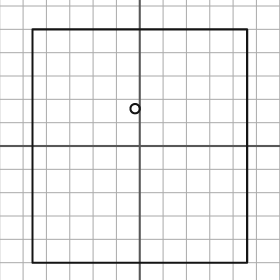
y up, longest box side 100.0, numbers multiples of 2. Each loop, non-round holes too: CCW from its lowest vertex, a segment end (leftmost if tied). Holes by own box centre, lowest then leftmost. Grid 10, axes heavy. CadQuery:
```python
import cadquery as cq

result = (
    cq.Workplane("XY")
    .moveTo(-46.0, -50.0)
    .lineTo(46.0, -50.0)
    .lineTo(46.0, 50.0)
    .lineTo(-46.0, 50.0)
    .close()
    .moveTo(-2.0, 16.0)
    .circle(2.0)
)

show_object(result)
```